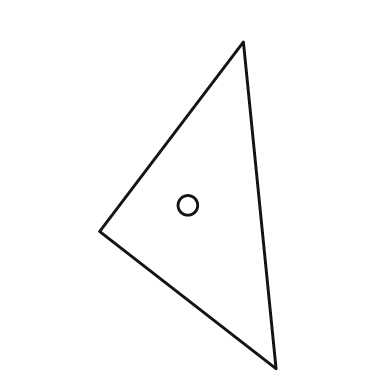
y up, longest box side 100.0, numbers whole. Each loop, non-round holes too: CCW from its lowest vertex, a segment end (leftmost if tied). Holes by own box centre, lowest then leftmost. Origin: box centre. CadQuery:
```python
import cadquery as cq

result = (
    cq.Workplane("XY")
    .moveTo(27.0, -50.0)
    .lineTo(17.0, 50.0)
    .lineTo(-27.0, -8.0)
    .close()
    .moveTo(0.0, 0.0)
    .circle(3.0)
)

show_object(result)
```